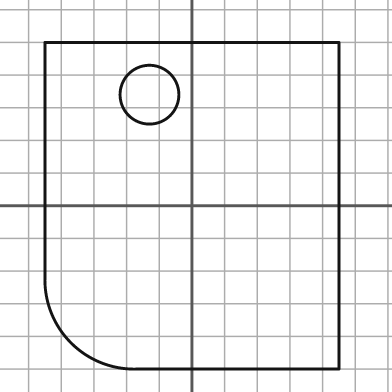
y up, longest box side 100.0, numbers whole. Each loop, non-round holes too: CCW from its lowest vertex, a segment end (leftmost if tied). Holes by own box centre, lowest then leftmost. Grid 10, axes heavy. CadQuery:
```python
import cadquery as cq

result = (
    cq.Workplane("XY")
    .moveTo(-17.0, -50.0)
    .lineTo(45.0, -50.0)
    .lineTo(45.0, 50.0)
    .lineTo(-45.0, 50.0)
    .lineTo(-45.0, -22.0)
    .threePointArc((-37.0, -42.0), (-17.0, -50.0))
    .close()
    .moveTo(-13.0, 34.0)
    .circle(9.0)
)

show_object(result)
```